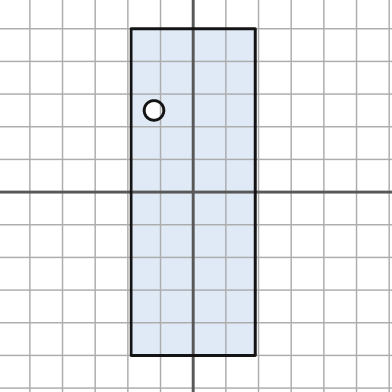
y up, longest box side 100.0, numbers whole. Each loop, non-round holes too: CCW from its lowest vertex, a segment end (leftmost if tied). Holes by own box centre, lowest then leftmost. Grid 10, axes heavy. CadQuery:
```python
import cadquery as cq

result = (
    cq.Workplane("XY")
    .moveTo(-19.0, -50.0)
    .lineTo(19.0, -50.0)
    .lineTo(19.0, 50.0)
    .lineTo(-19.0, 50.0)
    .close()
    .moveTo(-12.0, 25.0)
    .circle(3.0)
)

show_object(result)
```